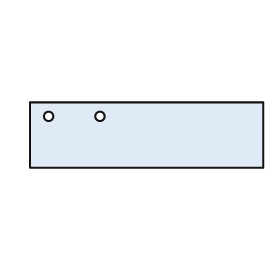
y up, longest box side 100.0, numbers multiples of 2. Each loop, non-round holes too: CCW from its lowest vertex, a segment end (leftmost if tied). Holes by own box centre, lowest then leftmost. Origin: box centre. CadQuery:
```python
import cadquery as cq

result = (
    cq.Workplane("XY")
    .moveTo(-50.0, -14.0)
    .lineTo(50.0, -14.0)
    .lineTo(50.0, 14.0)
    .lineTo(-50.0, 14.0)
    .close()
    .moveTo(-42.0, 8.0)
    .circle(2.0)
    .moveTo(-20.0, 8.0)
    .circle(2.0)
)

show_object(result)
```